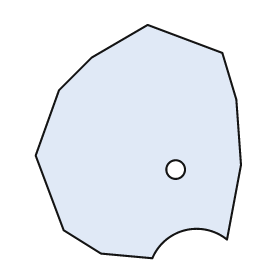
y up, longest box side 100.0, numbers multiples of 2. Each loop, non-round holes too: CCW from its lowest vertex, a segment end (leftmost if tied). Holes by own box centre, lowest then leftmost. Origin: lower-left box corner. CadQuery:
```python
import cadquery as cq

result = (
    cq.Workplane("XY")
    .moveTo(50.0, 0.0)
    .threePointArc((64.0, 12.0), (82.0, 8.0))
    .lineTo(88.0, 40.0)
    .lineTo(86.0, 68.0)
    .lineTo(80.0, 88.0)
    .lineTo(48.0, 100.0)
    .lineTo(24.0, 86.0)
    .lineTo(10.0, 72.0)
    .lineTo(0.0, 44.0)
    .lineTo(12.0, 12.0)
    .lineTo(28.0, 2.0)
    .close()
    .moveTo(60.0, 38.0)
    .circle(4.0)
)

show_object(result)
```